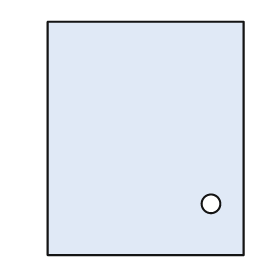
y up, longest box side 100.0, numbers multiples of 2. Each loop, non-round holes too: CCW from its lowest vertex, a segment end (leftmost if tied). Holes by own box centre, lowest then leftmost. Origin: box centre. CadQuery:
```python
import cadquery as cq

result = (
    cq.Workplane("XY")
    .moveTo(-42.0, -50.0)
    .lineTo(42.0, -50.0)
    .lineTo(42.0, 50.0)
    .lineTo(-42.0, 50.0)
    .close()
    .moveTo(28.0, -28.0)
    .circle(4.0)
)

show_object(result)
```